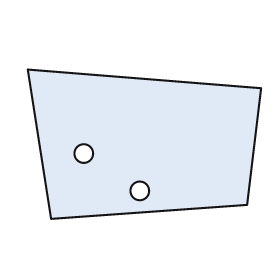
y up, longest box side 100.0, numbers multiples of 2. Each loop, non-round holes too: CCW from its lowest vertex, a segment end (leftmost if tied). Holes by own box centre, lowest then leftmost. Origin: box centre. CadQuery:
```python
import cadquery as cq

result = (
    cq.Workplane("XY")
    .moveTo(-40.0, -32.0)
    .lineTo(44.0, -26.0)
    .lineTo(50.0, 24.0)
    .lineTo(-50.0, 32.0)
    .close()
    .moveTo(-2.0, -20.0)
    .circle(4.0)
    .moveTo(-26.0, -4.0)
    .circle(4.0)
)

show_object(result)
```